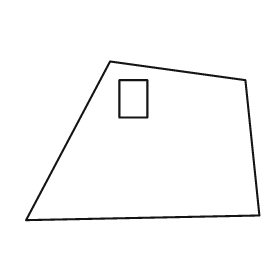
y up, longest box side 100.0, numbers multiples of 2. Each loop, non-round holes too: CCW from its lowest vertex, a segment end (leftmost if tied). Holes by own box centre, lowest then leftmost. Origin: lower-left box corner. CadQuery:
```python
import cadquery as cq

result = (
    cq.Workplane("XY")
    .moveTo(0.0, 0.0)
    .lineTo(100.0, 2.0)
    .lineTo(94.0, 60.0)
    .lineTo(36.0, 68.0)
    .close()
    .moveTo(40.0, 44.0)
    .lineTo(52.0, 44.0)
    .lineTo(52.0, 60.0)
    .lineTo(40.0, 60.0)
    .close()
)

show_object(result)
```